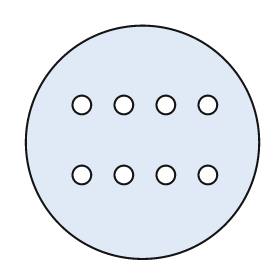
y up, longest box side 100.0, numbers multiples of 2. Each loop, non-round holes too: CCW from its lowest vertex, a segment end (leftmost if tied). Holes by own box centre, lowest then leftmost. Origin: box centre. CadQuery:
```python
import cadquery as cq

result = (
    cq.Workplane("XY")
    .moveTo(0.0, 0.0)
    .circle(50.0)
    .moveTo(-26.0, -14.0)
    .circle(4.0)
    .moveTo(-8.0, -14.0)
    .circle(4.0)
    .moveTo(10.0, -14.0)
    .circle(4.0)
    .moveTo(28.0, -14.0)
    .circle(4.0)
    .moveTo(-26.0, 16.0)
    .circle(4.0)
    .moveTo(-8.0, 16.0)
    .circle(4.0)
    .moveTo(10.0, 16.0)
    .circle(4.0)
    .moveTo(28.0, 16.0)
    .circle(4.0)
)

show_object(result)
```